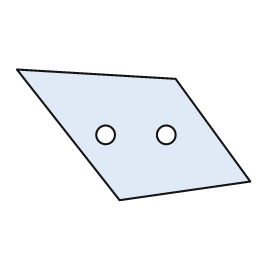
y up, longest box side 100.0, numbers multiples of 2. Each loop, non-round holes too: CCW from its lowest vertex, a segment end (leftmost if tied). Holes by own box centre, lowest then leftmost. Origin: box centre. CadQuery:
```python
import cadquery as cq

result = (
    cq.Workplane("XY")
    .moveTo(-6.0, -28.0)
    .lineTo(50.0, -20.0)
    .lineTo(18.0, 24.0)
    .lineTo(-50.0, 28.0)
    .close()
    .moveTo(-12.0, 0.0)
    .circle(4.0)
    .moveTo(14.0, 0.0)
    .circle(4.0)
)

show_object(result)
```